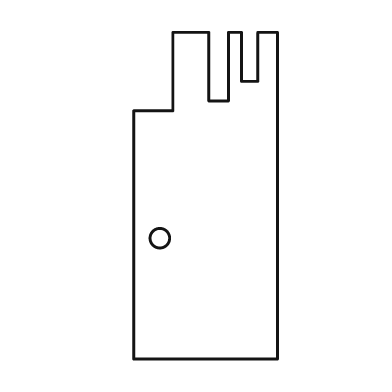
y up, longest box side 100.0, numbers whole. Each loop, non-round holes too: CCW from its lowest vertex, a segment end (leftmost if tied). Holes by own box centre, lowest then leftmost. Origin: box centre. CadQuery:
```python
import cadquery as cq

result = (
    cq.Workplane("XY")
    .moveTo(-22.0, -50.0)
    .lineTo(22.0, -50.0)
    .lineTo(22.0, 50.0)
    .lineTo(16.0, 50.0)
    .lineTo(16.0, 35.0)
    .lineTo(11.0, 35.0)
    .lineTo(11.0, 50.0)
    .lineTo(7.0, 50.0)
    .lineTo(7.0, 29.0)
    .lineTo(1.0, 29.0)
    .lineTo(1.0, 50.0)
    .lineTo(-10.0, 50.0)
    .lineTo(-10.0, 26.0)
    .lineTo(-22.0, 26.0)
    .close()
    .moveTo(-14.0, -13.0)
    .circle(3.0)
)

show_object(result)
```